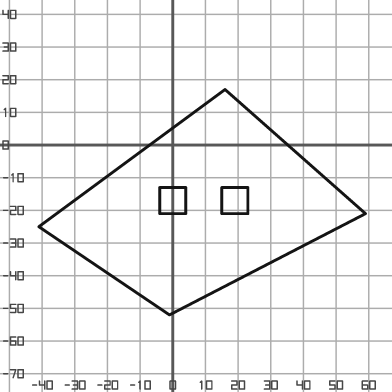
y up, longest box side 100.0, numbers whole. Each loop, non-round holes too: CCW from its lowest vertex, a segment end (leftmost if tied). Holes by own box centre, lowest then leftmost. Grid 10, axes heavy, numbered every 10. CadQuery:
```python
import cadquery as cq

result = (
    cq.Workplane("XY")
    .moveTo(-1.0, -52.0)
    .lineTo(59.0, -21.0)
    .lineTo(16.0, 17.0)
    .lineTo(-41.0, -25.0)
    .close()
    .moveTo(-4.0, -21.0)
    .lineTo(4.0, -21.0)
    .lineTo(4.0, -13.0)
    .lineTo(-4.0, -13.0)
    .close()
    .moveTo(15.0, -21.0)
    .lineTo(23.0, -21.0)
    .lineTo(23.0, -13.0)
    .lineTo(15.0, -13.0)
    .close()
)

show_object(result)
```